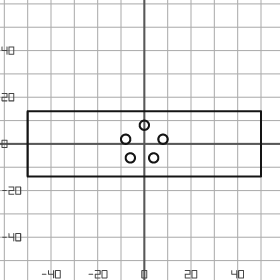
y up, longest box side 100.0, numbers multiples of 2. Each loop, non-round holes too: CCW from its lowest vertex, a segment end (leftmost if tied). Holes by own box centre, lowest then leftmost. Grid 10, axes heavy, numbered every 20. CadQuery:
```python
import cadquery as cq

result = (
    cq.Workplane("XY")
    .moveTo(-50.0, -14.0)
    .lineTo(50.0, -14.0)
    .lineTo(50.0, 14.0)
    .lineTo(-50.0, 14.0)
    .close()
    .moveTo(-6.0, -6.0)
    .circle(2.0)
    .moveTo(4.0, -6.0)
    .circle(2.0)
    .moveTo(-8.0, 2.0)
    .circle(2.0)
    .moveTo(8.0, 2.0)
    .circle(2.0)
    .moveTo(0.0, 8.0)
    .circle(2.0)
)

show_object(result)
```